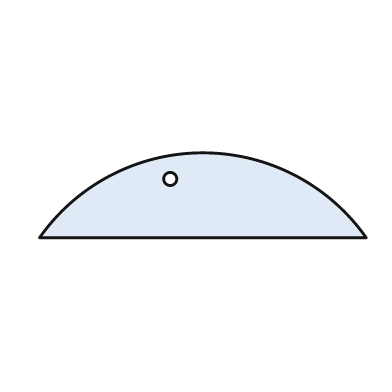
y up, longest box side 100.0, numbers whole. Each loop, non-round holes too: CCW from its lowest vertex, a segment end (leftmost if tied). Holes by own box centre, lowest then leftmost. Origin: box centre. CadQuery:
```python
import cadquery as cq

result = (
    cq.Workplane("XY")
    .moveTo(-50.0, -13.0)
    .lineTo(50.0, -13.0)
    .threePointArc((0.0, 13.0), (-50.0, -13.0))
    .close()
    .moveTo(-10.0, 5.0)
    .circle(2.0)
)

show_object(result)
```